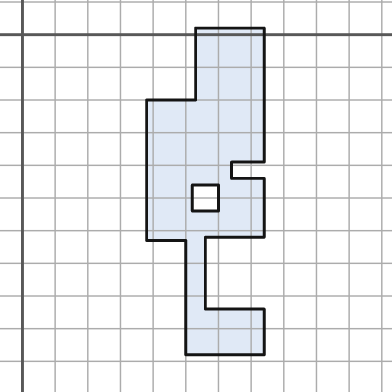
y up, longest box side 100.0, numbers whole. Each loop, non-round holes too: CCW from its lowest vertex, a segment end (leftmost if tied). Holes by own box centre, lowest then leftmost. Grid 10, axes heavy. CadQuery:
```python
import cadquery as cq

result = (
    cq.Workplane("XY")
    .moveTo(50.0, -98.0)
    .lineTo(74.0, -98.0)
    .lineTo(74.0, -84.0)
    .lineTo(56.0, -84.0)
    .lineTo(56.0, -62.0)
    .lineTo(74.0, -62.0)
    .lineTo(74.0, -44.0)
    .lineTo(64.0, -44.0)
    .lineTo(64.0, -39.0)
    .lineTo(74.0, -39.0)
    .lineTo(74.0, 2.0)
    .lineTo(53.0, 2.0)
    .lineTo(53.0, -20.0)
    .lineTo(38.0, -20.0)
    .lineTo(38.0, -63.0)
    .lineTo(50.0, -63.0)
    .close()
    .moveTo(52.0, -54.0)
    .lineTo(60.0, -54.0)
    .lineTo(60.0, -46.0)
    .lineTo(52.0, -46.0)
    .close()
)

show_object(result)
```